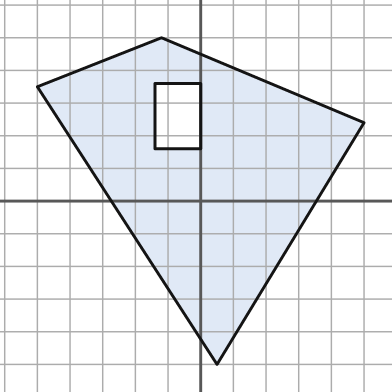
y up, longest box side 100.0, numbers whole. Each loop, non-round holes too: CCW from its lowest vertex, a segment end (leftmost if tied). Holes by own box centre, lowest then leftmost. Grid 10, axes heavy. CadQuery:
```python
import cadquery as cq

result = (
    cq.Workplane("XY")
    .moveTo(5.0, -50.0)
    .lineTo(50.0, 24.0)
    .lineTo(-12.0, 50.0)
    .lineTo(-50.0, 35.0)
    .close()
    .moveTo(-14.0, 16.0)
    .lineTo(0.0, 16.0)
    .lineTo(0.0, 36.0)
    .lineTo(-14.0, 36.0)
    .close()
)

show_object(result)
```